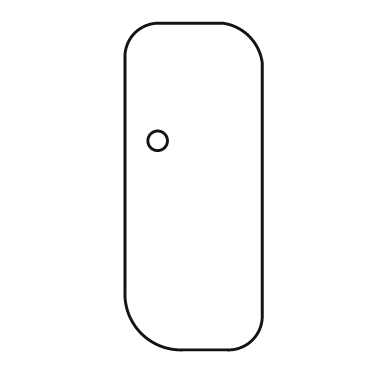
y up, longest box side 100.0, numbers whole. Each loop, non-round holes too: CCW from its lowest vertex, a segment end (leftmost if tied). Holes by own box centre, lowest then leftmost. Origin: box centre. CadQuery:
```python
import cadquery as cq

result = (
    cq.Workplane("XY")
    .moveTo(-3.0, -50.0)
    .lineTo(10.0, -50.0)
    .threePointArc((18.0, -47.0), (21.0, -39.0))
    .lineTo(21.0, 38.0)
    .threePointArc((17.0, 46.0), (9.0, 50.0))
    .lineTo(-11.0, 50.0)
    .threePointArc((-18.0, 47.0), (-21.0, 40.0))
    .lineTo(-21.0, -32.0)
    .threePointArc((-16.0, -45.0), (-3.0, -50.0))
    .close()
    .moveTo(-11.0, 14.0)
    .circle(3.0)
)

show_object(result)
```